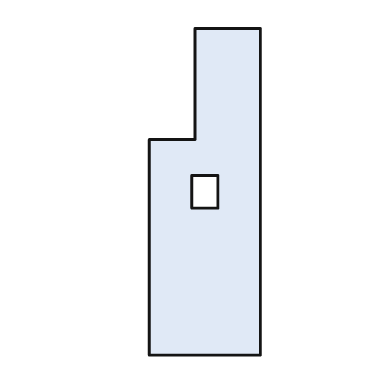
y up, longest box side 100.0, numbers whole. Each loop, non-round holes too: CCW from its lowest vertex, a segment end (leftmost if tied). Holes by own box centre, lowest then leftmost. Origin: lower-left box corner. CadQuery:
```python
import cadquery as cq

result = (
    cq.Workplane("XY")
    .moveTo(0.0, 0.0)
    .lineTo(34.0, 0.0)
    .lineTo(34.0, 100.0)
    .lineTo(14.0, 100.0)
    .lineTo(14.0, 66.0)
    .lineTo(0.0, 66.0)
    .close()
    .moveTo(13.0, 45.0)
    .lineTo(21.0, 45.0)
    .lineTo(21.0, 55.0)
    .lineTo(13.0, 55.0)
    .close()
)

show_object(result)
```